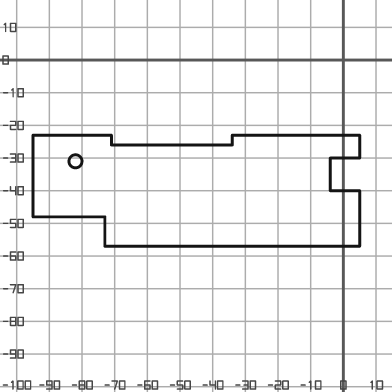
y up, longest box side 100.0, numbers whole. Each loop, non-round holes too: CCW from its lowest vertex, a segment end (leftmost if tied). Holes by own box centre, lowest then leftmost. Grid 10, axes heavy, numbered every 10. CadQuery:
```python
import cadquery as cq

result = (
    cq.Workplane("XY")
    .moveTo(-73.0, -57.0)
    .lineTo(5.0, -57.0)
    .lineTo(5.0, -40.0)
    .lineTo(-4.0, -40.0)
    .lineTo(-4.0, -30.0)
    .lineTo(5.0, -30.0)
    .lineTo(5.0, -23.0)
    .lineTo(-34.0, -23.0)
    .lineTo(-34.0, -26.0)
    .lineTo(-71.0, -26.0)
    .lineTo(-71.0, -23.0)
    .lineTo(-95.0, -23.0)
    .lineTo(-95.0, -48.0)
    .lineTo(-73.0, -48.0)
    .close()
    .moveTo(-82.0, -31.0)
    .circle(2.0)
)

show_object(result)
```